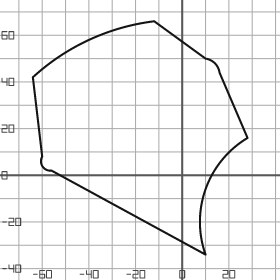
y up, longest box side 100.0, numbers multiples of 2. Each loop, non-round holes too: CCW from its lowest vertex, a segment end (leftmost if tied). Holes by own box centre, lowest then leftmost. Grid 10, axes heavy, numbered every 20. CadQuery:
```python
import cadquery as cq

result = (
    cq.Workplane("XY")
    .moveTo(10.0, -34.0)
    .threePointArc((10.0, -6.0), (28.0, 16.0))
    .lineTo(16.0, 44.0)
    .threePointArc((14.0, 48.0), (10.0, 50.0))
    .lineTo(-12.0, 66.0)
    .threePointArc((-40.0, 58.0), (-64.0, 42.0))
    .lineTo(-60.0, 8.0)
    .threePointArc((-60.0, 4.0), (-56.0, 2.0))
    .close()
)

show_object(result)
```